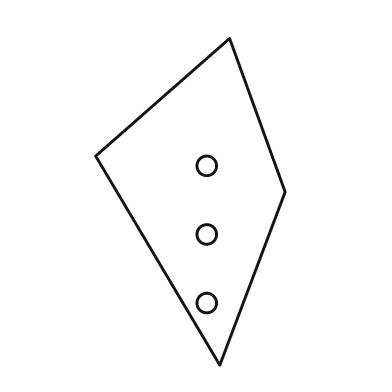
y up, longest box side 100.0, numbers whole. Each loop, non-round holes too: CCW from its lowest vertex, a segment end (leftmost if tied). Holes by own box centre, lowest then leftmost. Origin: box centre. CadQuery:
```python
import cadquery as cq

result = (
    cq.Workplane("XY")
    .moveTo(9.0, -50.0)
    .lineTo(29.0, 3.0)
    .lineTo(12.0, 50.0)
    .lineTo(-29.0, 14.0)
    .close()
    .moveTo(5.0, -31.0)
    .circle(3.0)
    .moveTo(5.0, -10.0)
    .circle(3.0)
    .moveTo(5.0, 11.0)
    .circle(3.0)
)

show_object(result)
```